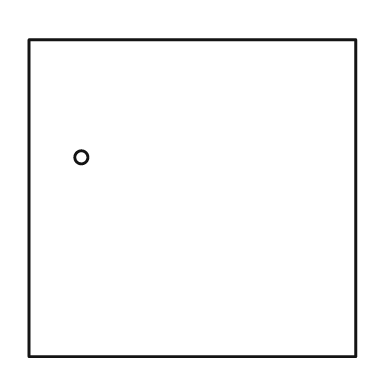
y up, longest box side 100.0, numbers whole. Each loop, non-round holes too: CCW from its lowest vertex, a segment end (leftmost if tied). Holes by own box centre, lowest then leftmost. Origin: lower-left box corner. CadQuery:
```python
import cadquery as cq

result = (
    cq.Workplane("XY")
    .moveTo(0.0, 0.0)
    .lineTo(100.0, 0.0)
    .lineTo(100.0, 97.0)
    .lineTo(0.0, 97.0)
    .close()
    .moveTo(16.0, 61.0)
    .circle(2.0)
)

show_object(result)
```